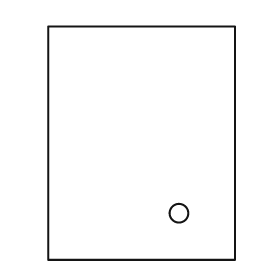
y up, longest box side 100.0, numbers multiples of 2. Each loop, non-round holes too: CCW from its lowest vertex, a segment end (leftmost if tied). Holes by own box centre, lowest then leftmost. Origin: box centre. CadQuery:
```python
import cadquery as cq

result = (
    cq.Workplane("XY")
    .moveTo(-40.0, -50.0)
    .lineTo(40.0, -50.0)
    .lineTo(40.0, 50.0)
    .lineTo(-40.0, 50.0)
    .close()
    .moveTo(16.0, -30.0)
    .circle(4.0)
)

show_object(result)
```